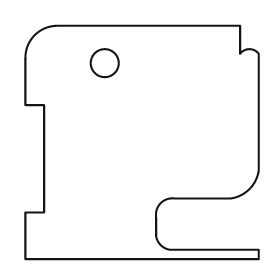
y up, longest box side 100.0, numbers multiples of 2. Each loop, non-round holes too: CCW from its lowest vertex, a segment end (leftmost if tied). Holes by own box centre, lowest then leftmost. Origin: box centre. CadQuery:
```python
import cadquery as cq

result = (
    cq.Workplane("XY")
    .moveTo(-50.0, -50.0)
    .lineTo(50.0, -50.0)
    .lineTo(50.0, -46.0)
    .lineTo(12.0, -46.0)
    .threePointArc((8.0, -44.0), (6.0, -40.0))
    .lineTo(6.0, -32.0)
    .threePointArc((8.0, -26.0), (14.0, -24.0))
    .lineTo(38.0, -24.0)
    .threePointArc((46.0, -20.0), (50.0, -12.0))
    .lineTo(50.0, 38.0)
    .threePointArc((46.0, 40.0), (42.0, 38.0))
    .lineTo(42.0, 50.0)
    .lineTo(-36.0, 50.0)
    .threePointArc((-46.0, 46.0), (-50.0, 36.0))
    .lineTo(-50.0, 16.0)
    .lineTo(-42.0, 16.0)
    .lineTo(-42.0, -30.0)
    .lineTo(-50.0, -30.0)
    .close()
    .moveTo(-16.0, 34.0)
    .circle(6.0)
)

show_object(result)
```